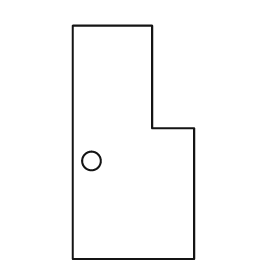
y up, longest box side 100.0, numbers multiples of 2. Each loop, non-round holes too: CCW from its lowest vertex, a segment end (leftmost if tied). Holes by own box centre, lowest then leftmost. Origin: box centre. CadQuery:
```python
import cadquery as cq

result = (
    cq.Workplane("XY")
    .moveTo(-26.0, -50.0)
    .lineTo(26.0, -50.0)
    .lineTo(26.0, 6.0)
    .lineTo(8.0, 6.0)
    .lineTo(8.0, 50.0)
    .lineTo(-26.0, 50.0)
    .close()
    .moveTo(-18.0, -8.0)
    .circle(4.0)
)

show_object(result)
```